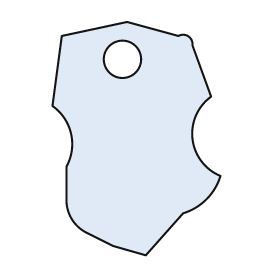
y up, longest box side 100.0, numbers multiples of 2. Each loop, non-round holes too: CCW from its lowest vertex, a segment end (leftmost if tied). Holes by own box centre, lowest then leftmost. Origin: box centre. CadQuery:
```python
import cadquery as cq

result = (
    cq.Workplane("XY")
    .moveTo(4.0, -50.0)
    .lineTo(20.0, -32.0)
    .threePointArc((30.0, -26.0), (36.0, -16.0))
    .threePointArc((24.0, 0.0), (32.0, 18.0))
    .lineTo(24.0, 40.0)
    .threePointArc((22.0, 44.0), (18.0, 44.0))
    .lineTo(-4.0, 50.0)
    .lineTo(-32.0, 44.0)
    .lineTo(-36.0, 14.0)
    .threePointArc((-28.0, 2.0), (-30.0, -12.0))
    .lineTo(-30.0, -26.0)
    .threePointArc((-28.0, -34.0), (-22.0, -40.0))
    .lineTo(-10.0, -46.0)
    .close()
    .moveTo(-6.0, 34.0)
    .circle(8.0)
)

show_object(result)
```